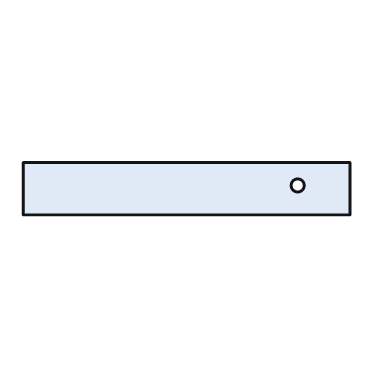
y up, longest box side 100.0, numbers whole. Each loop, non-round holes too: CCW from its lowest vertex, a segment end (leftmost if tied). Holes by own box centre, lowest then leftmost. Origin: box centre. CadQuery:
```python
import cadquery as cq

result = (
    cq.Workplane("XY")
    .moveTo(-50.0, -8.0)
    .lineTo(50.0, -8.0)
    .lineTo(50.0, 8.0)
    .lineTo(-50.0, 8.0)
    .close()
    .moveTo(34.0, 1.0)
    .circle(2.0)
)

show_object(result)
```